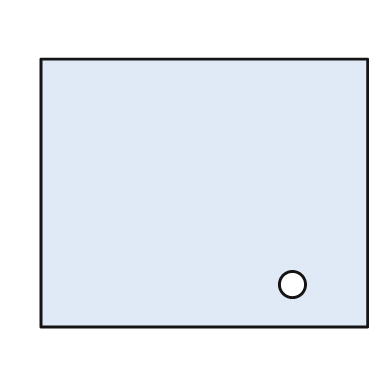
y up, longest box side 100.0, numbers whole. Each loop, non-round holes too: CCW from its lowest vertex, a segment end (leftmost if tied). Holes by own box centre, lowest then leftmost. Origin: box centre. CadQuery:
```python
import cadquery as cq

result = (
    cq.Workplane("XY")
    .moveTo(-50.0, -41.0)
    .lineTo(50.0, -41.0)
    .lineTo(50.0, 41.0)
    .lineTo(-50.0, 41.0)
    .close()
    .moveTo(27.0, -28.0)
    .circle(4.0)
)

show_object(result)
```